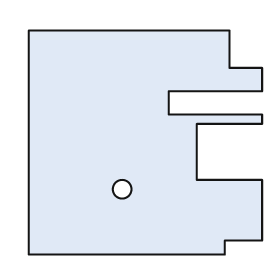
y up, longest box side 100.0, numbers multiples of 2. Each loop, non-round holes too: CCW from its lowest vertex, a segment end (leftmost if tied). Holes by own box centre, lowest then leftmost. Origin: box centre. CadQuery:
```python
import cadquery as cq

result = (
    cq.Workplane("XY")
    .moveTo(-50.0, -48.0)
    .lineTo(34.0, -48.0)
    .lineTo(34.0, -42.0)
    .lineTo(50.0, -42.0)
    .lineTo(50.0, -16.0)
    .lineTo(22.0, -16.0)
    .lineTo(22.0, 8.0)
    .lineTo(50.0, 8.0)
    .lineTo(50.0, 12.0)
    .lineTo(10.0, 12.0)
    .lineTo(10.0, 22.0)
    .lineTo(50.0, 22.0)
    .lineTo(50.0, 32.0)
    .lineTo(36.0, 32.0)
    .lineTo(36.0, 48.0)
    .lineTo(-50.0, 48.0)
    .close()
    .moveTo(-10.0, -20.0)
    .circle(4.0)
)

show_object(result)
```